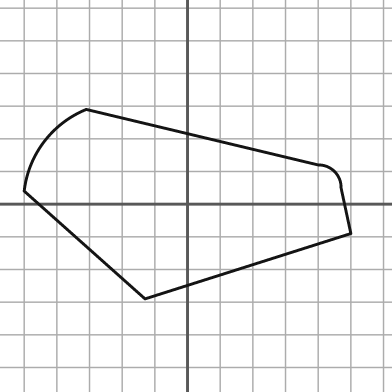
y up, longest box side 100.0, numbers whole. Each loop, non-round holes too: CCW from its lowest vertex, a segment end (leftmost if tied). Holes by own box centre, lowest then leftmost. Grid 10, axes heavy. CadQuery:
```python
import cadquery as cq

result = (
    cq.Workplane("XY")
    .moveTo(-13.0, -29.0)
    .lineTo(50.0, -9.0)
    .lineTo(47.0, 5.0)
    .threePointArc((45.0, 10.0), (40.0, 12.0))
    .lineTo(-31.0, 29.0)
    .threePointArc((-44.0, 19.0), (-50.0, 4.0))
    .close()
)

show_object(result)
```